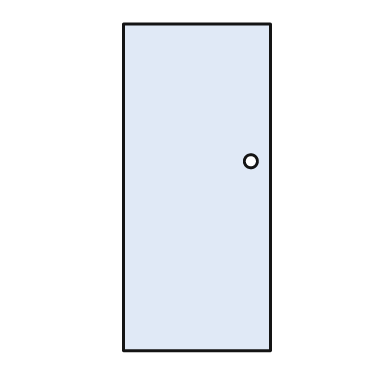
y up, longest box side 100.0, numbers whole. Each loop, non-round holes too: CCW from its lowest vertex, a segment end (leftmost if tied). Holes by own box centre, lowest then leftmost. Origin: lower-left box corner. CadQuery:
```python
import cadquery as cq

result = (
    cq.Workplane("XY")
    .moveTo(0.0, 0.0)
    .lineTo(45.0, 0.0)
    .lineTo(45.0, 100.0)
    .lineTo(0.0, 100.0)
    .close()
    .moveTo(39.0, 58.0)
    .circle(2.0)
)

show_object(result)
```